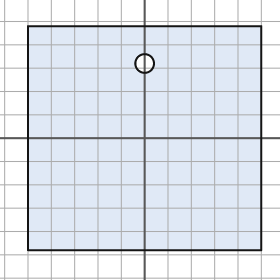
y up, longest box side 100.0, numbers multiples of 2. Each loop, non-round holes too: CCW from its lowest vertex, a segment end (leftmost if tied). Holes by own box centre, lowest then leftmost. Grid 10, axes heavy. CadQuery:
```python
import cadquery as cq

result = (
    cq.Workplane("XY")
    .moveTo(-50.0, -48.0)
    .lineTo(50.0, -48.0)
    .lineTo(50.0, 48.0)
    .lineTo(-50.0, 48.0)
    .close()
    .moveTo(0.0, 32.0)
    .circle(4.0)
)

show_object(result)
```